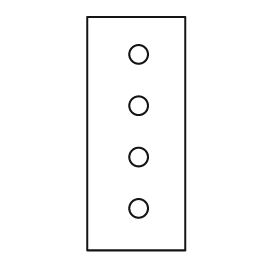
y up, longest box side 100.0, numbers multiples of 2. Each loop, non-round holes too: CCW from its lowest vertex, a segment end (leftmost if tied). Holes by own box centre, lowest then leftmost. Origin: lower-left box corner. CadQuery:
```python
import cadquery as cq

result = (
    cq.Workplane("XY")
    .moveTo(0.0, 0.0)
    .lineTo(42.0, 0.0)
    .lineTo(42.0, 100.0)
    .lineTo(0.0, 100.0)
    .close()
    .moveTo(22.0, 18.0)
    .circle(4.0)
    .moveTo(22.0, 40.0)
    .circle(4.0)
    .moveTo(22.0, 62.0)
    .circle(4.0)
    .moveTo(22.0, 84.0)
    .circle(4.0)
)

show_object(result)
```